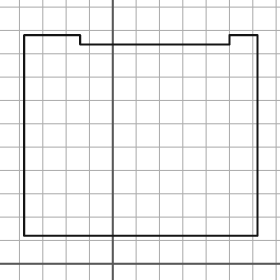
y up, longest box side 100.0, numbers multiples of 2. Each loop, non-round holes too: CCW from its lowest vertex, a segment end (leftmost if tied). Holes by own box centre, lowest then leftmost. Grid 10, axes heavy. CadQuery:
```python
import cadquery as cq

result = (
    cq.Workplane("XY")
    .moveTo(-38.0, 12.0)
    .lineTo(62.0, 12.0)
    .lineTo(62.0, 98.0)
    .lineTo(50.0, 98.0)
    .lineTo(50.0, 94.0)
    .lineTo(-14.0, 94.0)
    .lineTo(-14.0, 98.0)
    .lineTo(-38.0, 98.0)
    .close()
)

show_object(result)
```